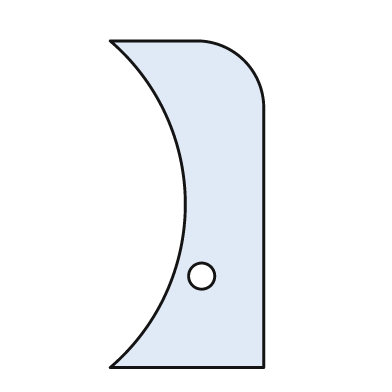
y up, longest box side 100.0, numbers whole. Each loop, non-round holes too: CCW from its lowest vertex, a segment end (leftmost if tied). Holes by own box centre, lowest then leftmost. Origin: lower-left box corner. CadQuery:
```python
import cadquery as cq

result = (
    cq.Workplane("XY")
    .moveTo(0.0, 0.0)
    .lineTo(47.0, 0.0)
    .lineTo(47.0, 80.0)
    .threePointArc((41.0, 94.0), (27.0, 100.0))
    .lineTo(0.0, 100.0)
    .threePointArc((23.0, 50.0), (0.0, 0.0))
    .close()
    .moveTo(28.0, 28.0)
    .circle(4.0)
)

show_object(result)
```